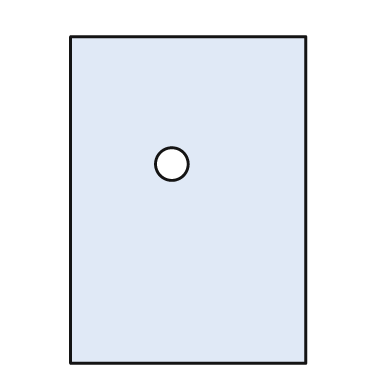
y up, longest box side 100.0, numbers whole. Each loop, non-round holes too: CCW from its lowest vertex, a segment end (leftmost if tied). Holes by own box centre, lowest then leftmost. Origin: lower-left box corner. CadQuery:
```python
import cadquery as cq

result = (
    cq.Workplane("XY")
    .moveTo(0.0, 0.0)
    .lineTo(72.0, 0.0)
    .lineTo(72.0, 100.0)
    .lineTo(0.0, 100.0)
    .close()
    .moveTo(31.0, 61.0)
    .circle(5.0)
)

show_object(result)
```